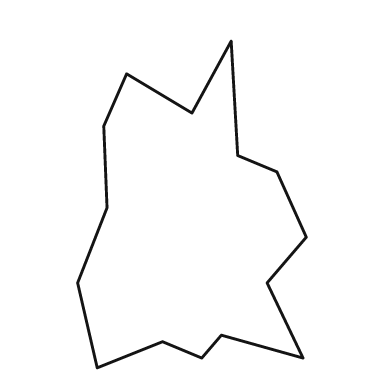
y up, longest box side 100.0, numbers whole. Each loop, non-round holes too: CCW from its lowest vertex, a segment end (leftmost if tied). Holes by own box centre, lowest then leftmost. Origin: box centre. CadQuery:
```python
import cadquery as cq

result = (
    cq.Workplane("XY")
    .moveTo(-29.0, -50.0)
    .lineTo(-9.0, -42.0)
    .lineTo(3.0, -47.0)
    .lineTo(9.0, -40.0)
    .lineTo(34.0, -47.0)
    .lineTo(23.0, -24.0)
    .lineTo(35.0, -10.0)
    .lineTo(26.0, 10.0)
    .lineTo(14.0, 15.0)
    .lineTo(12.0, 50.0)
    .lineTo(0.0, 28.0)
    .lineTo(-20.0, 40.0)
    .lineTo(-27.0, 24.0)
    .lineTo(-26.0, -1.0)
    .lineTo(-35.0, -24.0)
    .close()
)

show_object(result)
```